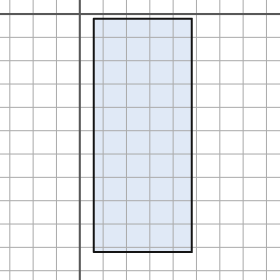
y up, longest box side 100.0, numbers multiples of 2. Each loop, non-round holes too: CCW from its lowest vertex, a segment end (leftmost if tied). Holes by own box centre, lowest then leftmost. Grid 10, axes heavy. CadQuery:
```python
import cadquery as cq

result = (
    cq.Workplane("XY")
    .moveTo(6.0, -102.0)
    .lineTo(48.0, -102.0)
    .lineTo(48.0, -2.0)
    .lineTo(6.0, -2.0)
    .close()
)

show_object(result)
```